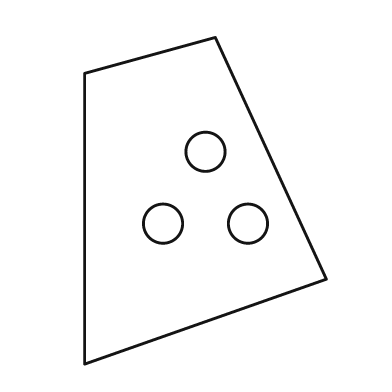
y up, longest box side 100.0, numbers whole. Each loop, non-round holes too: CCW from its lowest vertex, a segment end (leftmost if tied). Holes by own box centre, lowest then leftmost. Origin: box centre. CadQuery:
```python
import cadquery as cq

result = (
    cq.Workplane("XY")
    .moveTo(-37.0, -50.0)
    .lineTo(37.0, -24.0)
    .lineTo(3.0, 50.0)
    .lineTo(-37.0, 39.0)
    .close()
    .moveTo(-13.0, -7.0)
    .circle(6.0)
    .moveTo(13.0, -7.0)
    .circle(6.0)
    .moveTo(0.0, 15.0)
    .circle(6.0)
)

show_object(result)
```